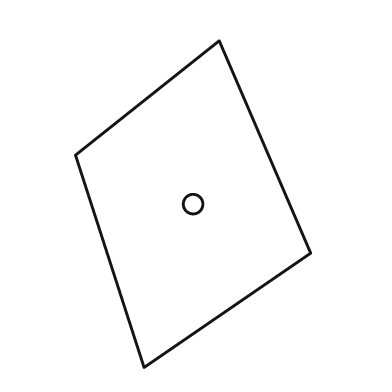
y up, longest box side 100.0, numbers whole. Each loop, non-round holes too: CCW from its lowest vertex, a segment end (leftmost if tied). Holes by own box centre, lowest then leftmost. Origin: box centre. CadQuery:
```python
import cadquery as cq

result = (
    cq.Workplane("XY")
    .moveTo(-15.0, -50.0)
    .lineTo(36.0, -15.0)
    .lineTo(8.0, 50.0)
    .lineTo(-36.0, 15.0)
    .close()
    .moveTo(0.0, 0.0)
    .circle(3.0)
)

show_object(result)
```